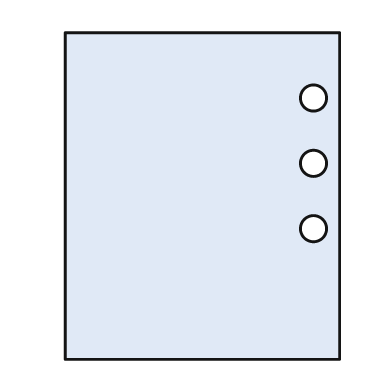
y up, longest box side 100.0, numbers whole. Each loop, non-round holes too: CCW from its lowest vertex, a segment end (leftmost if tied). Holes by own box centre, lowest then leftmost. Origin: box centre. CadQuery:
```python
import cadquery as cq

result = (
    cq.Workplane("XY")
    .moveTo(-42.0, -50.0)
    .lineTo(42.0, -50.0)
    .lineTo(42.0, 50.0)
    .lineTo(-42.0, 50.0)
    .close()
    .moveTo(34.0, -10.0)
    .circle(4.0)
    .moveTo(34.0, 10.0)
    .circle(4.0)
    .moveTo(34.0, 30.0)
    .circle(4.0)
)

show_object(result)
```